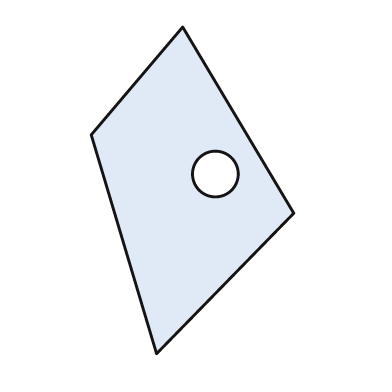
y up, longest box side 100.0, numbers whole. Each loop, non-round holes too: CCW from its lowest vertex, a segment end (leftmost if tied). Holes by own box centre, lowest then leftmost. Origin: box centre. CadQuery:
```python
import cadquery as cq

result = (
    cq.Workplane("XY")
    .moveTo(-11.0, -50.0)
    .lineTo(31.0, -7.0)
    .lineTo(-3.0, 50.0)
    .lineTo(-31.0, 17.0)
    .close()
    .moveTo(7.0, 5.0)
    .circle(7.0)
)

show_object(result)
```